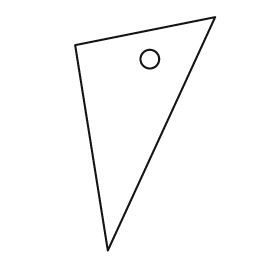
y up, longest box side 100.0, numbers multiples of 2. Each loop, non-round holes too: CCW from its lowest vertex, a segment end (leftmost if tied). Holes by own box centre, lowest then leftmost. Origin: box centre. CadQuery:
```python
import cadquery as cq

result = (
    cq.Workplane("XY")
    .moveTo(-16.0, -50.0)
    .lineTo(30.0, 50.0)
    .lineTo(-30.0, 38.0)
    .close()
    .moveTo(2.0, 32.0)
    .circle(4.0)
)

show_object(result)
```